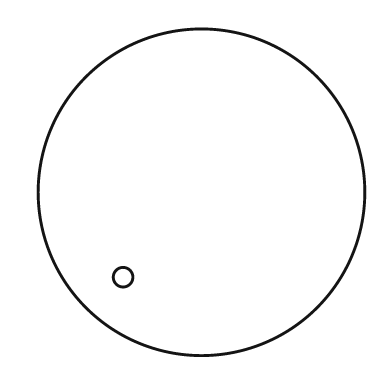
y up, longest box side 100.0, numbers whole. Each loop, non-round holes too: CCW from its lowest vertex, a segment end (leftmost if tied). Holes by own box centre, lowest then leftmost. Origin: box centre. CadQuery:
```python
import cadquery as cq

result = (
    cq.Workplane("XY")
    .moveTo(0.0, 0.0)
    .circle(50.0)
    .moveTo(-24.0, -26.0)
    .circle(3.0)
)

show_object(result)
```